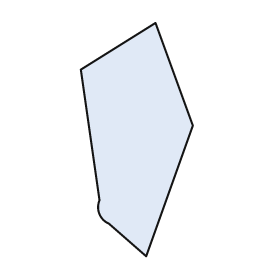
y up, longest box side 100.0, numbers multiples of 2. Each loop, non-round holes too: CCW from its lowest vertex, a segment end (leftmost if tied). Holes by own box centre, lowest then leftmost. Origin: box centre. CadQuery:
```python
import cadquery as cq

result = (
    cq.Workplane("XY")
    .moveTo(4.0, -50.0)
    .lineTo(24.0, 6.0)
    .lineTo(8.0, 50.0)
    .lineTo(-24.0, 30.0)
    .lineTo(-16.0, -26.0)
    .threePointArc((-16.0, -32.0), (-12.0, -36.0))
    .close()
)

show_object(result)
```